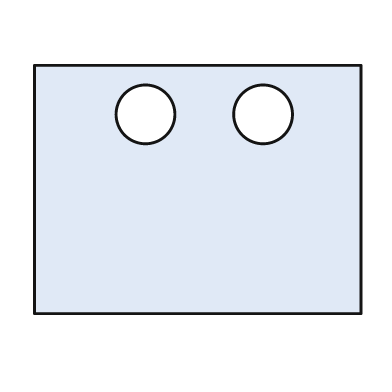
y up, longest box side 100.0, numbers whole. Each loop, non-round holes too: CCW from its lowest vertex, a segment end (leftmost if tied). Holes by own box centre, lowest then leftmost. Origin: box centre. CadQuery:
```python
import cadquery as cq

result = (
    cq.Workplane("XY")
    .moveTo(-50.0, -38.0)
    .lineTo(50.0, -38.0)
    .lineTo(50.0, 38.0)
    .lineTo(-50.0, 38.0)
    .close()
    .moveTo(-16.0, 23.0)
    .circle(9.0)
    .moveTo(20.0, 23.0)
    .circle(9.0)
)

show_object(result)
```